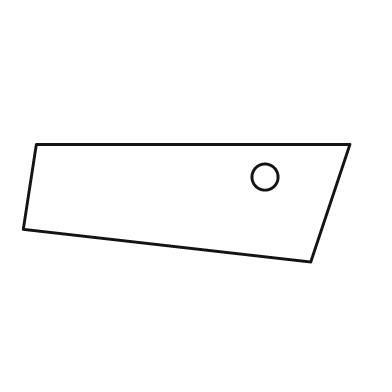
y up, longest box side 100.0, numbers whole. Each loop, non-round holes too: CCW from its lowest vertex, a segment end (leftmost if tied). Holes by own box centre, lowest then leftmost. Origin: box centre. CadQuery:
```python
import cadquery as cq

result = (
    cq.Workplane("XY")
    .moveTo(38.0, -18.0)
    .lineTo(50.0, 18.0)
    .lineTo(-46.0, 18.0)
    .lineTo(-50.0, -8.0)
    .close()
    .moveTo(24.0, 8.0)
    .circle(4.0)
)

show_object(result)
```